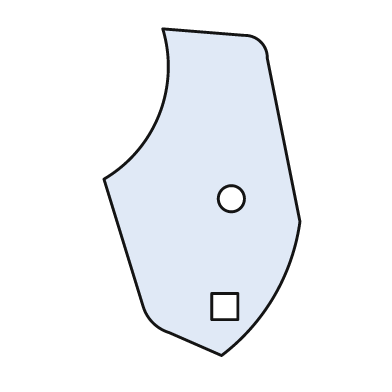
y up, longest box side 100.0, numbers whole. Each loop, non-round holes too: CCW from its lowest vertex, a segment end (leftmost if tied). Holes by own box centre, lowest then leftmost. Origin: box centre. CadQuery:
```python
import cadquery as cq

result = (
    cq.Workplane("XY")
    .moveTo(6.0, -50.0)
    .threePointArc((22.0, -32.0), (30.0, -9.0))
    .lineTo(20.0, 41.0)
    .threePointArc((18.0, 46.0), (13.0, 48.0))
    .lineTo(-12.0, 50.0)
    .threePointArc((-13.0, 24.0), (-30.0, 4.0))
    .lineTo(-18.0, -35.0)
    .threePointArc((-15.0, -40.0), (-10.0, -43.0))
    .close()
    .moveTo(3.0, -39.0)
    .lineTo(11.0, -39.0)
    .lineTo(11.0, -31.0)
    .lineTo(3.0, -31.0)
    .close()
    .moveTo(9.0, -2.0)
    .circle(4.0)
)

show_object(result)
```